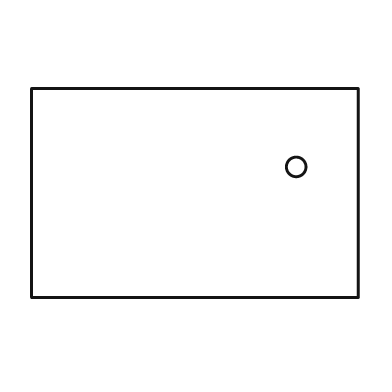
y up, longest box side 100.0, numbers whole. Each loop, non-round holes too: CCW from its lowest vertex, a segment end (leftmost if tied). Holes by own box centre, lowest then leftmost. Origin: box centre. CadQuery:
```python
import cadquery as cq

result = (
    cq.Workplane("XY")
    .moveTo(-50.0, -32.0)
    .lineTo(50.0, -32.0)
    .lineTo(50.0, 32.0)
    .lineTo(-50.0, 32.0)
    .close()
    .moveTo(31.0, 8.0)
    .circle(3.0)
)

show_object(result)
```